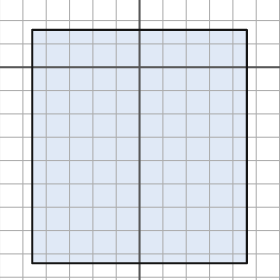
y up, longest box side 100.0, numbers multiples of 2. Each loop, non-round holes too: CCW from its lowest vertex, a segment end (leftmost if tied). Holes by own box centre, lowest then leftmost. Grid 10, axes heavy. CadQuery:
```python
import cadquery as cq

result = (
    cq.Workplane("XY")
    .moveTo(-46.0, -84.0)
    .lineTo(46.0, -84.0)
    .lineTo(46.0, 16.0)
    .lineTo(-46.0, 16.0)
    .close()
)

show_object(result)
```